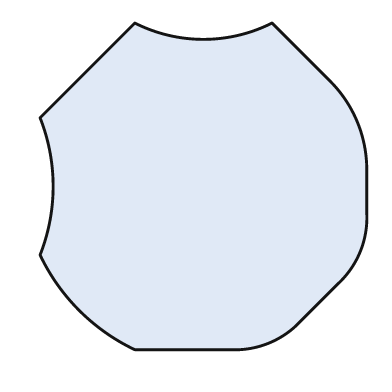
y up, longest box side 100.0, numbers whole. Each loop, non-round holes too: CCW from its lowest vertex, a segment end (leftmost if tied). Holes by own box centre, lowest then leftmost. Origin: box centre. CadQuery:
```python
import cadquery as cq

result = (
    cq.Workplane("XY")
    .moveTo(-21.0, -50.0)
    .lineTo(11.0, -50.0)
    .threePointArc((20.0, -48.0), (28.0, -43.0))
    .lineTo(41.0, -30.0)
    .threePointArc((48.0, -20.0), (50.0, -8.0))
    .lineTo(50.0, 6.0)
    .threePointArc((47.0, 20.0), (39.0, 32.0))
    .lineTo(21.0, 50.0)
    .threePointArc((0.0, 45.0), (-21.0, 50.0))
    .lineTo(-50.0, 21.0)
    .threePointArc((-46.0, 0.0), (-50.0, -21.0))
    .threePointArc((-38.0, -38.0), (-21.0, -50.0))
    .close()
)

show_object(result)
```